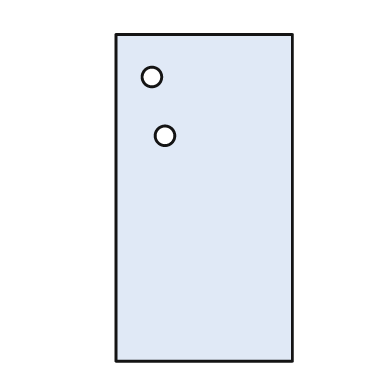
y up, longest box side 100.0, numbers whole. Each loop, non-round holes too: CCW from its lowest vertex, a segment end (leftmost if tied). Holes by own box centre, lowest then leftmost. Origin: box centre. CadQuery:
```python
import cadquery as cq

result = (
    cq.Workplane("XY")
    .moveTo(-27.0, -50.0)
    .lineTo(27.0, -50.0)
    .lineTo(27.0, 50.0)
    .lineTo(-27.0, 50.0)
    .close()
    .moveTo(-12.0, 19.0)
    .circle(3.0)
    .moveTo(-16.0, 37.0)
    .circle(3.0)
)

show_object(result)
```